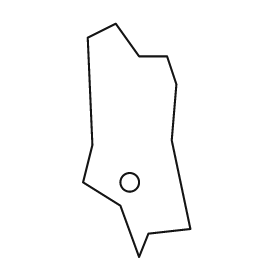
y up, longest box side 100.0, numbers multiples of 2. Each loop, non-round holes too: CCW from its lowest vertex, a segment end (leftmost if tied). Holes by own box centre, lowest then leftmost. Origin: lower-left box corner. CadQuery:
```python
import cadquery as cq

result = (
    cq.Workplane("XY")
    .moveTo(24.0, 0.0)
    .lineTo(28.0, 10.0)
    .lineTo(46.0, 12.0)
    .lineTo(38.0, 50.0)
    .lineTo(40.0, 74.0)
    .lineTo(36.0, 86.0)
    .lineTo(24.0, 86.0)
    .lineTo(14.0, 100.0)
    .lineTo(2.0, 94.0)
    .lineTo(4.0, 48.0)
    .lineTo(0.0, 32.0)
    .lineTo(16.0, 22.0)
    .close()
    .moveTo(20.0, 32.0)
    .circle(4.0)
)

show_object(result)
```